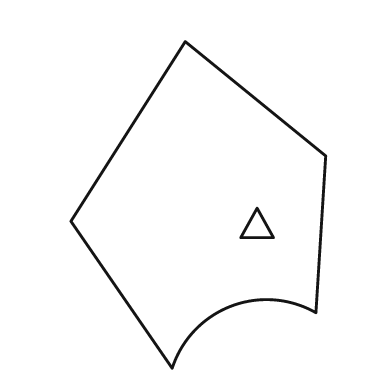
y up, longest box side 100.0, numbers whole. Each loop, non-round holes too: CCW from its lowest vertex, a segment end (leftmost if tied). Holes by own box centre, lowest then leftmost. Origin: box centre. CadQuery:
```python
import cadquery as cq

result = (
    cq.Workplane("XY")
    .moveTo(-8.0, -50.0)
    .threePointArc((10.0, -31.0), (36.0, -33.0))
    .lineTo(39.0, 15.0)
    .lineTo(-4.0, 50.0)
    .lineTo(-39.0, -5.0)
    .close()
    .moveTo(13.0, -10.0)
    .lineTo(23.0, -10.0)
    .lineTo(18.0, -1.0)
    .close()
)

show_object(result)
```